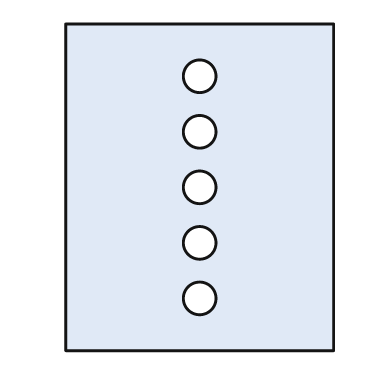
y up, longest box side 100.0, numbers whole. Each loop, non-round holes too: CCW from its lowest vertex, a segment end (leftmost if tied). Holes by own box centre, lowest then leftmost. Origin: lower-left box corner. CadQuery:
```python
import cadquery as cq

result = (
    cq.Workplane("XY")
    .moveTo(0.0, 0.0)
    .lineTo(82.0, 0.0)
    .lineTo(82.0, 100.0)
    .lineTo(0.0, 100.0)
    .close()
    .moveTo(41.0, 16.0)
    .circle(5.0)
    .moveTo(41.0, 33.0)
    .circle(5.0)
    .moveTo(41.0, 50.0)
    .circle(5.0)
    .moveTo(41.0, 67.0)
    .circle(5.0)
    .moveTo(41.0, 84.0)
    .circle(5.0)
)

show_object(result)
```